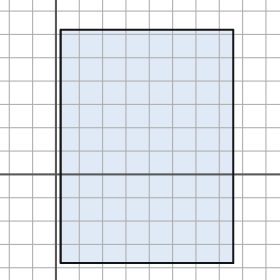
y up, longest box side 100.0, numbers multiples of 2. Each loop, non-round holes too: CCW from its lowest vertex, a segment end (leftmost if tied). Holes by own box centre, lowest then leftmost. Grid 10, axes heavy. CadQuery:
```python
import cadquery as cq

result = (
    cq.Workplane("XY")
    .moveTo(2.0, -38.0)
    .lineTo(76.0, -38.0)
    .lineTo(76.0, 62.0)
    .lineTo(2.0, 62.0)
    .close()
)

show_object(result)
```